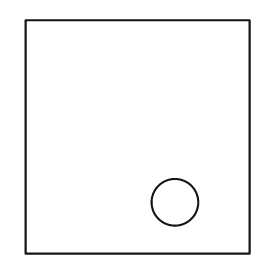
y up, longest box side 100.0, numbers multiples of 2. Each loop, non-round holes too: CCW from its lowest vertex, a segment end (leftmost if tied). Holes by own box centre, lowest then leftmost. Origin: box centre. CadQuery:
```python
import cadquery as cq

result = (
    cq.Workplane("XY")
    .moveTo(-48.0, -50.0)
    .lineTo(48.0, -50.0)
    .lineTo(48.0, 50.0)
    .lineTo(-48.0, 50.0)
    .close()
    .moveTo(16.0, -28.0)
    .circle(10.0)
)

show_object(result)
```